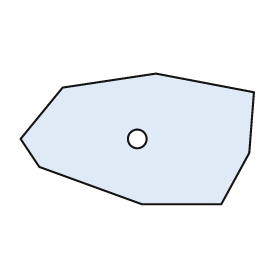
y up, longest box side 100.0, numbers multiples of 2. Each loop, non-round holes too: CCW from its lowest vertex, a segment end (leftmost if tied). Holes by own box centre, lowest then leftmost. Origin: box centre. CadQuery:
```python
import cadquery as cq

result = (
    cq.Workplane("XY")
    .moveTo(2.0, -28.0)
    .lineTo(36.0, -28.0)
    .lineTo(48.0, -6.0)
    .lineTo(50.0, 20.0)
    .lineTo(8.0, 28.0)
    .lineTo(-32.0, 22.0)
    .lineTo(-50.0, 0.0)
    .lineTo(-42.0, -12.0)
    .close()
    .moveTo(0.0, 0.0)
    .circle(4.0)
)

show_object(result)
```